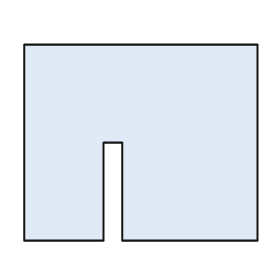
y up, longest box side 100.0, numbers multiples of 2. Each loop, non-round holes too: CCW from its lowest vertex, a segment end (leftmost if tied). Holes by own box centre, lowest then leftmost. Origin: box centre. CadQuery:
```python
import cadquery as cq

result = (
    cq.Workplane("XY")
    .moveTo(-50.0, -42.0)
    .lineTo(-16.0, -42.0)
    .lineTo(-16.0, 0.0)
    .lineTo(-8.0, 0.0)
    .lineTo(-8.0, -42.0)
    .lineTo(50.0, -42.0)
    .lineTo(50.0, 42.0)
    .lineTo(-50.0, 42.0)
    .close()
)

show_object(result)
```